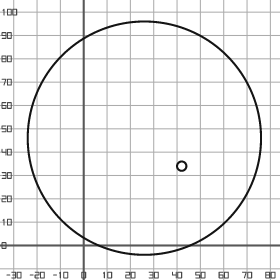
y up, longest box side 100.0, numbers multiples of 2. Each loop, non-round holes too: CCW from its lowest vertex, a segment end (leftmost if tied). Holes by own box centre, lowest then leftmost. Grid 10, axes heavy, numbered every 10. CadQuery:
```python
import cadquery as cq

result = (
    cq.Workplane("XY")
    .moveTo(26.0, 46.0)
    .circle(50.0)
    .moveTo(42.0, 34.0)
    .circle(2.0)
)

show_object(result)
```